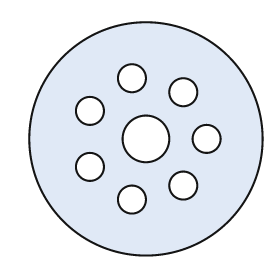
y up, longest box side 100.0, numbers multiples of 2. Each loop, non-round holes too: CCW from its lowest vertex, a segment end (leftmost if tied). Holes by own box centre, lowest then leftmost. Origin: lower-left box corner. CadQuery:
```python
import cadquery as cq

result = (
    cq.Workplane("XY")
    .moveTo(50.0, 50.0)
    .circle(50.0)
    .moveTo(44.0, 24.0)
    .circle(6.0)
    .moveTo(66.0, 30.0)
    .circle(6.0)
    .moveTo(26.0, 38.0)
    .circle(6.0)
    .moveTo(50.0, 50.0)
    .circle(10.0)
    .moveTo(76.0, 50.0)
    .circle(6.0)
    .moveTo(26.0, 62.0)
    .circle(6.0)
    .moveTo(66.0, 70.0)
    .circle(6.0)
    .moveTo(44.0, 76.0)
    .circle(6.0)
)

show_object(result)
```